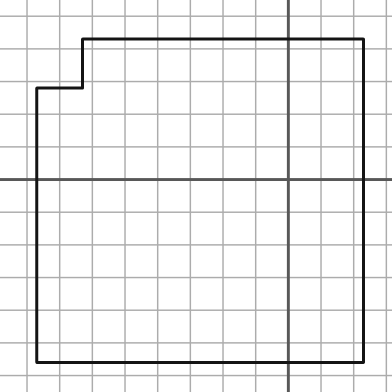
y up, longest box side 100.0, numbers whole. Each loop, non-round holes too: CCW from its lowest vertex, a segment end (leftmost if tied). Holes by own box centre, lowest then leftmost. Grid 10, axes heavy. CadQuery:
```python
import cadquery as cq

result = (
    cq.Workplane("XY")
    .moveTo(-77.0, -56.0)
    .lineTo(23.0, -56.0)
    .lineTo(23.0, 43.0)
    .lineTo(-63.0, 43.0)
    .lineTo(-63.0, 28.0)
    .lineTo(-77.0, 28.0)
    .close()
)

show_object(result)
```